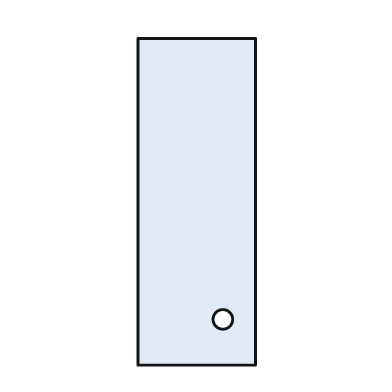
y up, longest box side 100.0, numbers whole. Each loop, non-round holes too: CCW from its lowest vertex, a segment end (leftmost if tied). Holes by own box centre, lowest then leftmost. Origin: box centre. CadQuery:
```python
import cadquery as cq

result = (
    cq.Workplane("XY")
    .moveTo(-18.0, -50.0)
    .lineTo(18.0, -50.0)
    .lineTo(18.0, 50.0)
    .lineTo(-18.0, 50.0)
    .close()
    .moveTo(8.0, -36.0)
    .circle(3.0)
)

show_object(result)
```